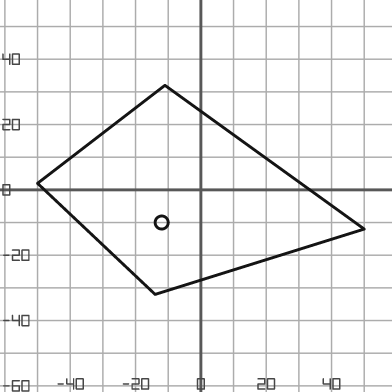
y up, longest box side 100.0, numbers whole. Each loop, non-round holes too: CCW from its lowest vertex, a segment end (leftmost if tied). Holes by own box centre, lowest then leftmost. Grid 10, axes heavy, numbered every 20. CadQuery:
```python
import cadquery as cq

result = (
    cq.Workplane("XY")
    .moveTo(-14.0, -32.0)
    .lineTo(50.0, -12.0)
    .lineTo(-11.0, 32.0)
    .lineTo(-50.0, 2.0)
    .close()
    .moveTo(-12.0, -10.0)
    .circle(2.0)
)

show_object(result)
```